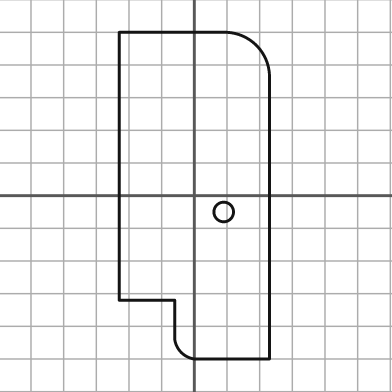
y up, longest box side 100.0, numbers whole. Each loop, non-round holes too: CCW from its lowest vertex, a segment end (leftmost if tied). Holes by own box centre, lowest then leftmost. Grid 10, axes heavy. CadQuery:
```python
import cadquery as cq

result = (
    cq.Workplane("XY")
    .moveTo(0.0, -50.0)
    .lineTo(23.0, -50.0)
    .lineTo(23.0, 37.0)
    .threePointArc((19.0, 46.0), (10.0, 50.0))
    .lineTo(-23.0, 50.0)
    .lineTo(-23.0, -32.0)
    .lineTo(-6.0, -32.0)
    .lineTo(-6.0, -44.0)
    .threePointArc((-4.0, -48.0), (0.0, -50.0))
    .close()
    .moveTo(9.0, -5.0)
    .circle(3.0)
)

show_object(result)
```